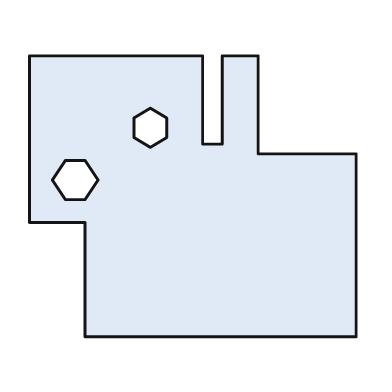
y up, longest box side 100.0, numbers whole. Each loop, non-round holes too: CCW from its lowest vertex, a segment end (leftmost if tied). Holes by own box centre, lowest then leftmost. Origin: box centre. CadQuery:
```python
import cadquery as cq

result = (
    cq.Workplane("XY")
    .moveTo(-33.0, -43.0)
    .lineTo(50.0, -43.0)
    .lineTo(50.0, 13.0)
    .lineTo(20.0, 13.0)
    .lineTo(20.0, 43.0)
    .lineTo(9.0, 43.0)
    .lineTo(9.0, 16.0)
    .lineTo(3.0, 16.0)
    .lineTo(3.0, 43.0)
    .lineTo(-50.0, 43.0)
    .lineTo(-50.0, -8.0)
    .lineTo(-33.0, -8.0)
    .close()
    .moveTo(-39.0, -1.0)
    .lineTo(-33.0, -1.0)
    .lineTo(-29.0, 5.0)
    .lineTo(-33.0, 11.0)
    .lineTo(-39.0, 11.0)
    .lineTo(-43.0, 5.0)
    .close()
    .moveTo(-13.0, 15.0)
    .lineTo(-8.0, 18.0)
    .lineTo(-8.0, 24.0)
    .lineTo(-13.0, 27.0)
    .lineTo(-18.0, 24.0)
    .lineTo(-18.0, 18.0)
    .close()
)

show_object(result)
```